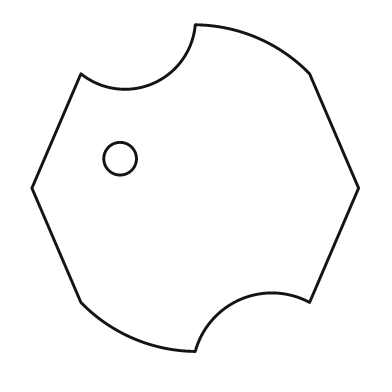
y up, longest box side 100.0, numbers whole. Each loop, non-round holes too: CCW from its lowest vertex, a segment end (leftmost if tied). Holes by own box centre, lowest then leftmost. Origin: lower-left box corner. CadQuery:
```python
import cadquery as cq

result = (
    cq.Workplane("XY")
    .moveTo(50.0, 0.0)
    .threePointArc((64.0, 16.0), (85.0, 15.0))
    .lineTo(100.0, 50.0)
    .lineTo(85.0, 85.0)
    .threePointArc((69.0, 96.0), (50.0, 100.0))
    .threePointArc((37.0, 82.0), (15.0, 85.0))
    .lineTo(0.0, 50.0)
    .lineTo(15.0, 15.0)
    .threePointArc((31.0, 4.0), (50.0, 0.0))
    .close()
    .moveTo(27.0, 59.0)
    .circle(5.0)
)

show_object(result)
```